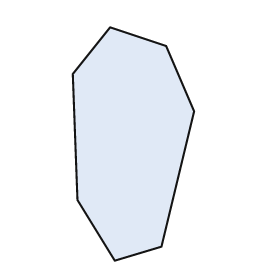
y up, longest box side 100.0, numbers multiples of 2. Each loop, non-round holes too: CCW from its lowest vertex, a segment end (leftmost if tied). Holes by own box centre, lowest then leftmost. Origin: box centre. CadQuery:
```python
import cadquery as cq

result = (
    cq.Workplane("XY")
    .moveTo(-8.0, -50.0)
    .lineTo(12.0, -44.0)
    .lineTo(26.0, 14.0)
    .lineTo(14.0, 42.0)
    .lineTo(-10.0, 50.0)
    .lineTo(-26.0, 30.0)
    .lineTo(-24.0, -24.0)
    .close()
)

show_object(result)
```